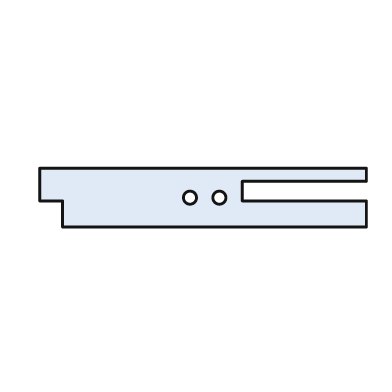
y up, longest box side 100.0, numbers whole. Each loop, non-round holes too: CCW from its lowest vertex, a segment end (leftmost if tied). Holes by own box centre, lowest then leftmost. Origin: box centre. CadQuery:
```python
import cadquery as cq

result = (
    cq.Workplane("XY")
    .moveTo(-43.0, -9.0)
    .lineTo(50.0, -9.0)
    .lineTo(50.0, -1.0)
    .lineTo(12.0, -1.0)
    .lineTo(12.0, 5.0)
    .lineTo(50.0, 5.0)
    .lineTo(50.0, 9.0)
    .lineTo(-50.0, 9.0)
    .lineTo(-50.0, -1.0)
    .lineTo(-43.0, -1.0)
    .close()
    .moveTo(-4.0, 0.0)
    .circle(2.0)
    .moveTo(5.0, 0.0)
    .circle(2.0)
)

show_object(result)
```